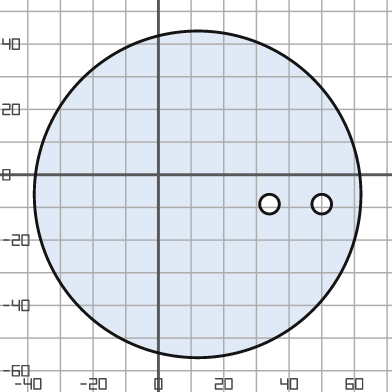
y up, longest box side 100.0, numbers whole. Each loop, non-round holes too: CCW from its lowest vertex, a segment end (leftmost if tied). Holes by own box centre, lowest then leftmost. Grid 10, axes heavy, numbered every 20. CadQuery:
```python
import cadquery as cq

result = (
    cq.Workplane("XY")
    .moveTo(12.0, -6.0)
    .circle(50.0)
    .moveTo(34.0, -9.0)
    .circle(3.0)
    .moveTo(50.0, -9.0)
    .circle(3.0)
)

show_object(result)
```